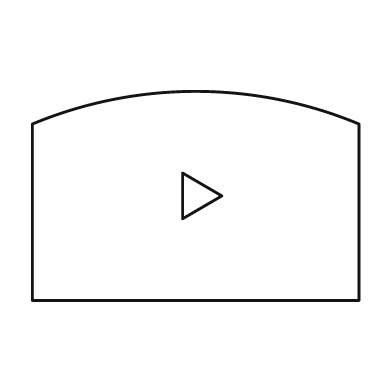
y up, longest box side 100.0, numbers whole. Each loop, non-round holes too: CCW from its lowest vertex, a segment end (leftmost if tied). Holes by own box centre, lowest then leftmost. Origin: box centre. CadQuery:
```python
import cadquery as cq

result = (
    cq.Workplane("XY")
    .moveTo(-50.0, -32.0)
    .lineTo(50.0, -32.0)
    .lineTo(50.0, 22.0)
    .threePointArc((0.0, 32.0), (-50.0, 22.0))
    .close()
    .moveTo(-4.0, -7.0)
    .lineTo(8.0, 0.0)
    .lineTo(-4.0, 7.0)
    .close()
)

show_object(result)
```